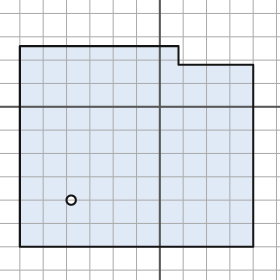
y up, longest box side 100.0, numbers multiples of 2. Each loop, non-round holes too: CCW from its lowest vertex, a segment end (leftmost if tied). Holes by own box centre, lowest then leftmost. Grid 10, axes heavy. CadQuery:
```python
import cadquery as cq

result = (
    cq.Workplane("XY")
    .moveTo(-60.0, -60.0)
    .lineTo(40.0, -60.0)
    .lineTo(40.0, 18.0)
    .lineTo(8.0, 18.0)
    .lineTo(8.0, 26.0)
    .lineTo(-60.0, 26.0)
    .close()
    .moveTo(-38.0, -40.0)
    .circle(2.0)
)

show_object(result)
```